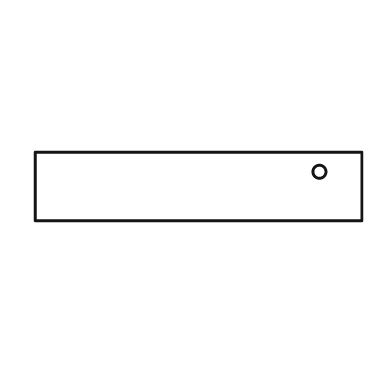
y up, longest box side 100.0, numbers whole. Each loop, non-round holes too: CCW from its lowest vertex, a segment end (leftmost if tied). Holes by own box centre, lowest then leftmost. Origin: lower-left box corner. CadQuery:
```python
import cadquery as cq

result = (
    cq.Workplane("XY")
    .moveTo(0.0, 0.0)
    .lineTo(100.0, 0.0)
    .lineTo(100.0, 21.0)
    .lineTo(0.0, 21.0)
    .close()
    .moveTo(87.0, 15.0)
    .circle(2.0)
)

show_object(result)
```